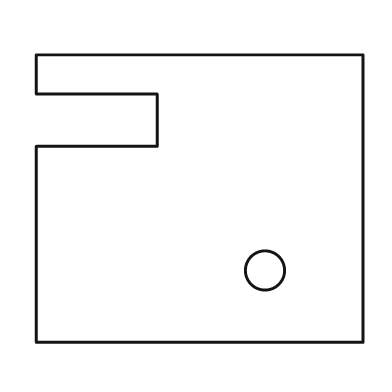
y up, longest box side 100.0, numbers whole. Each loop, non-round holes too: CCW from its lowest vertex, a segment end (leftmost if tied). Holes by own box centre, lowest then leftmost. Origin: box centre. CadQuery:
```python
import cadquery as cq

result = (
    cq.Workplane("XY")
    .moveTo(-50.0, -44.0)
    .lineTo(50.0, -44.0)
    .lineTo(50.0, 44.0)
    .lineTo(-50.0, 44.0)
    .lineTo(-50.0, 32.0)
    .lineTo(-13.0, 32.0)
    .lineTo(-13.0, 16.0)
    .lineTo(-50.0, 16.0)
    .close()
    .moveTo(20.0, -22.0)
    .circle(6.0)
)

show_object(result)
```